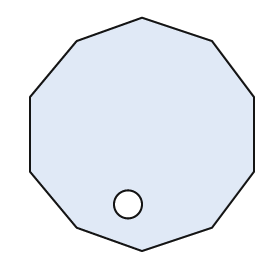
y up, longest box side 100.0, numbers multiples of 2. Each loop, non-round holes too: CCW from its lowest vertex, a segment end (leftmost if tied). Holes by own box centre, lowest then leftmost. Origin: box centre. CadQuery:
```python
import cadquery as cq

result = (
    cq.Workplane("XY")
    .moveTo(0.0, -50.0)
    .lineTo(30.0, -40.0)
    .lineTo(48.0, -16.0)
    .lineTo(48.0, 16.0)
    .lineTo(30.0, 40.0)
    .lineTo(0.0, 50.0)
    .lineTo(-28.0, 40.0)
    .lineTo(-48.0, 16.0)
    .lineTo(-48.0, -16.0)
    .lineTo(-28.0, -40.0)
    .close()
    .moveTo(-6.0, -30.0)
    .circle(6.0)
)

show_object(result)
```